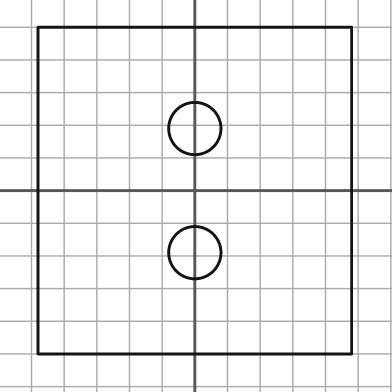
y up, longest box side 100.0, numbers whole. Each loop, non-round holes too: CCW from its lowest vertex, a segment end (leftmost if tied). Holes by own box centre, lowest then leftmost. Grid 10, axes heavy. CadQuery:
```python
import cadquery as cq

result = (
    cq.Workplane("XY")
    .moveTo(-48.0, -50.0)
    .lineTo(48.0, -50.0)
    .lineTo(48.0, 50.0)
    .lineTo(-48.0, 50.0)
    .close()
    .moveTo(0.0, -19.0)
    .circle(8.0)
    .moveTo(0.0, 19.0)
    .circle(8.0)
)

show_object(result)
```